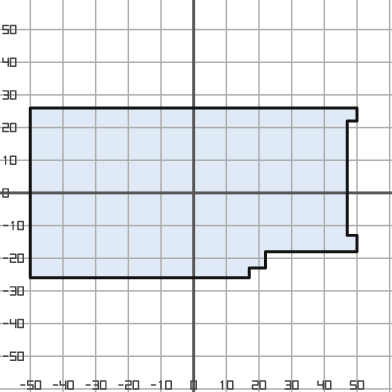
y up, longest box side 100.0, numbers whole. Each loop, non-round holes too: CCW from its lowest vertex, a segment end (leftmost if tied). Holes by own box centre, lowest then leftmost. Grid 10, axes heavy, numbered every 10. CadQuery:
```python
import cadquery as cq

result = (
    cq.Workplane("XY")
    .moveTo(-50.0, -26.0)
    .lineTo(17.0, -26.0)
    .lineTo(17.0, -23.0)
    .lineTo(22.0, -23.0)
    .lineTo(22.0, -18.0)
    .lineTo(50.0, -18.0)
    .lineTo(50.0, -13.0)
    .lineTo(47.0, -13.0)
    .lineTo(47.0, 22.0)
    .lineTo(50.0, 22.0)
    .lineTo(50.0, 26.0)
    .lineTo(-50.0, 26.0)
    .close()
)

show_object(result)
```